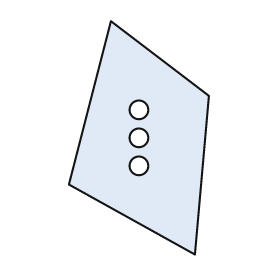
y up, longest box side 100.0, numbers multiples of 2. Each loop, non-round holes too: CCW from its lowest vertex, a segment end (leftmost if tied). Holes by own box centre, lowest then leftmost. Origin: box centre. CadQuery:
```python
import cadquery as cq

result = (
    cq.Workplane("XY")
    .moveTo(24.0, -50.0)
    .lineTo(30.0, 18.0)
    .lineTo(-12.0, 50.0)
    .lineTo(-30.0, -20.0)
    .close()
    .moveTo(0.0, -12.0)
    .circle(4.0)
    .moveTo(0.0, 0.0)
    .circle(4.0)
    .moveTo(0.0, 12.0)
    .circle(4.0)
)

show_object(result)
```